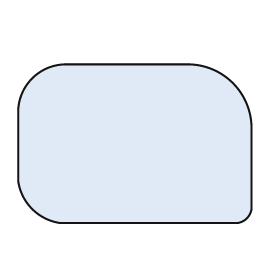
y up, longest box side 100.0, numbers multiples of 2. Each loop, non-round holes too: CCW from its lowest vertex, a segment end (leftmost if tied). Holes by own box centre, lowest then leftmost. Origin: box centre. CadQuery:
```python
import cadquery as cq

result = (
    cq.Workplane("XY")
    .moveTo(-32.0, -34.0)
    .lineTo(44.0, -34.0)
    .threePointArc((48.0, -32.0), (50.0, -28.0))
    .lineTo(50.0, 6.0)
    .threePointArc((42.0, 26.0), (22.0, 34.0))
    .lineTo(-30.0, 34.0)
    .threePointArc((-44.0, 28.0), (-50.0, 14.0))
    .lineTo(-50.0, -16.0)
    .threePointArc((-44.0, -28.0), (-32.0, -34.0))
    .close()
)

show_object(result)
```